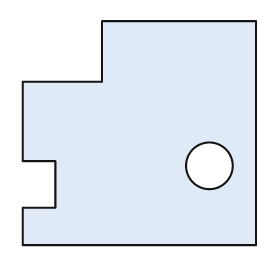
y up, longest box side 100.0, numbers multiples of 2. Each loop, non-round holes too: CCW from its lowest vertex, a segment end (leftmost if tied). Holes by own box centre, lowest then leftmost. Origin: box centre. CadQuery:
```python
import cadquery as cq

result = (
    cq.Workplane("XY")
    .moveTo(-50.0, -48.0)
    .lineTo(50.0, -48.0)
    .lineTo(50.0, 48.0)
    .lineTo(-16.0, 48.0)
    .lineTo(-16.0, 22.0)
    .lineTo(-50.0, 22.0)
    .lineTo(-50.0, -12.0)
    .lineTo(-36.0, -12.0)
    .lineTo(-36.0, -32.0)
    .lineTo(-50.0, -32.0)
    .close()
    .moveTo(30.0, -14.0)
    .circle(10.0)
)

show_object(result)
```